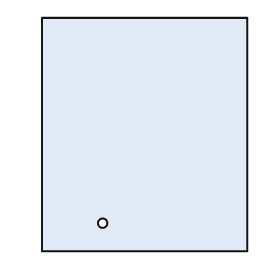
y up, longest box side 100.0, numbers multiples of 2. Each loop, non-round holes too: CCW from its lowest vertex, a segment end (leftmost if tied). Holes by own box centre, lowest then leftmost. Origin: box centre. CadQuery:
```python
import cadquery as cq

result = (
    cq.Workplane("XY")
    .moveTo(-44.0, -50.0)
    .lineTo(44.0, -50.0)
    .lineTo(44.0, 50.0)
    .lineTo(-44.0, 50.0)
    .close()
    .moveTo(-18.0, -38.0)
    .circle(2.0)
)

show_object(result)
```